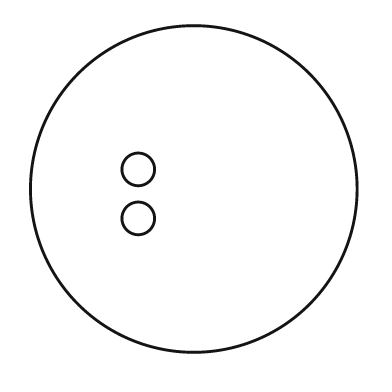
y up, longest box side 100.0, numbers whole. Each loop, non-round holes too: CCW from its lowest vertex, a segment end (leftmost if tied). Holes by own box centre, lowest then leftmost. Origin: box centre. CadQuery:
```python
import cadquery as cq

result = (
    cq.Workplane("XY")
    .moveTo(0.0, 0.0)
    .circle(50.0)
    .moveTo(-17.0, -9.0)
    .circle(5.0)
    .moveTo(-17.0, 6.0)
    .circle(5.0)
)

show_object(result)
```